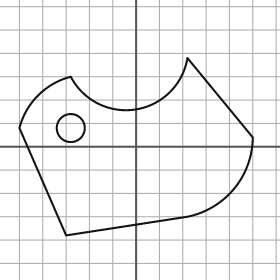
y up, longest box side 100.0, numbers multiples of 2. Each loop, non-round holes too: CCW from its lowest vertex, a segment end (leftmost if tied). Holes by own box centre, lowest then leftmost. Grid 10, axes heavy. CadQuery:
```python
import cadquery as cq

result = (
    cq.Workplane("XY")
    .moveTo(-30.0, -38.0)
    .lineTo(22.0, -30.0)
    .threePointArc((42.0, -18.0), (50.0, 4.0))
    .lineTo(22.0, 38.0)
    .threePointArc((0.0, 16.0), (-28.0, 30.0))
    .threePointArc((-42.0, 22.0), (-50.0, 8.0))
    .close()
    .moveTo(-28.0, 8.0)
    .circle(6.0)
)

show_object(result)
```